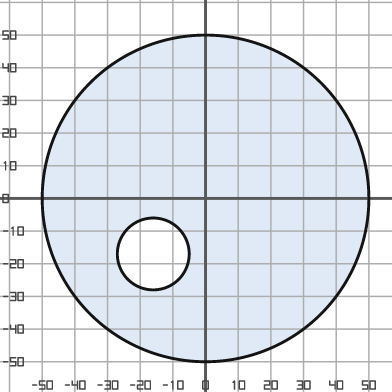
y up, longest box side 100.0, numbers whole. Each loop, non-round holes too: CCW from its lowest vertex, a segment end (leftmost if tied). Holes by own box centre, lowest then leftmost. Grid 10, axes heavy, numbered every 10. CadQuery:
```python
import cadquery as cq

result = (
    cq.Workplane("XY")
    .moveTo(0.0, 0.0)
    .circle(50.0)
    .moveTo(-16.0, -17.0)
    .circle(11.0)
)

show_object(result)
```